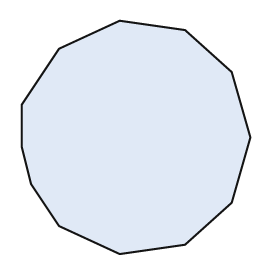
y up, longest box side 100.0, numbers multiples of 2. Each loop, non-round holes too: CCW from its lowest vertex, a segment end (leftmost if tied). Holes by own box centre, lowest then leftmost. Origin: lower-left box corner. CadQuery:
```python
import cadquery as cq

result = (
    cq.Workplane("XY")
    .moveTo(42.0, 0.0)
    .lineTo(70.0, 4.0)
    .lineTo(90.0, 22.0)
    .lineTo(98.0, 50.0)
    .lineTo(90.0, 78.0)
    .lineTo(70.0, 96.0)
    .lineTo(42.0, 100.0)
    .lineTo(16.0, 88.0)
    .lineTo(0.0, 64.0)
    .lineTo(0.0, 46.0)
    .lineTo(4.0, 30.0)
    .lineTo(16.0, 12.0)
    .close()
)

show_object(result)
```